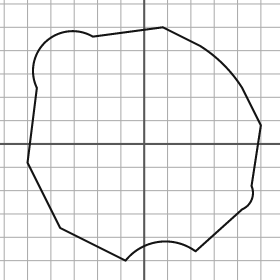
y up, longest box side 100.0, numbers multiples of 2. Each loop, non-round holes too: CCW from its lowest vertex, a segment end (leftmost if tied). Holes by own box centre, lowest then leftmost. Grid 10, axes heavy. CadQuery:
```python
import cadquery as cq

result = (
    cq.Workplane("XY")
    .moveTo(-8.0, -50.0)
    .threePointArc((6.0, -42.0), (22.0, -46.0))
    .lineTo(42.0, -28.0)
    .threePointArc((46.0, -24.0), (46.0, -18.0))
    .lineTo(50.0, 8.0)
    .lineTo(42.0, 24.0)
    .threePointArc((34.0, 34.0), (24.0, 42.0))
    .lineTo(8.0, 50.0)
    .lineTo(-22.0, 46.0)
    .threePointArc((-42.0, 44.0), (-46.0, 24.0))
    .lineTo(-50.0, -8.0)
    .lineTo(-36.0, -36.0)
    .close()
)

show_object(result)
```